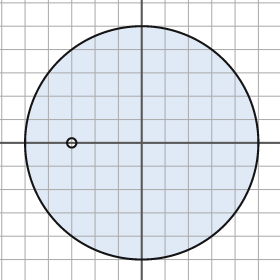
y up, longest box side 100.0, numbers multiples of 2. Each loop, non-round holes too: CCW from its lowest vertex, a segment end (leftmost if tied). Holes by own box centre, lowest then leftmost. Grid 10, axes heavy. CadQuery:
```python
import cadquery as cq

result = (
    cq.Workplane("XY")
    .moveTo(0.0, 0.0)
    .circle(50.0)
    .moveTo(-30.0, 0.0)
    .circle(2.0)
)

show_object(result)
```